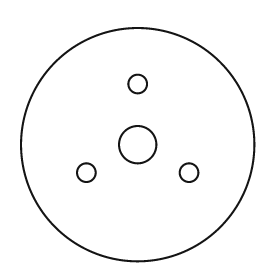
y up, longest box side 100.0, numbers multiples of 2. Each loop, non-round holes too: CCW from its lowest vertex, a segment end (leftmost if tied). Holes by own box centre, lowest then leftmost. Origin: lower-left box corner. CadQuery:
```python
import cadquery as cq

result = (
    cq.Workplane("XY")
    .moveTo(50.0, 50.0)
    .circle(50.0)
    .moveTo(28.0, 38.0)
    .circle(4.0)
    .moveTo(72.0, 38.0)
    .circle(4.0)
    .moveTo(50.0, 50.0)
    .circle(8.0)
    .moveTo(50.0, 76.0)
    .circle(4.0)
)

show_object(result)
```